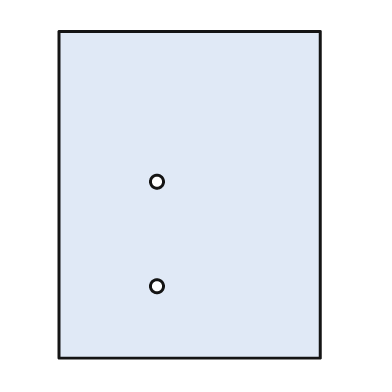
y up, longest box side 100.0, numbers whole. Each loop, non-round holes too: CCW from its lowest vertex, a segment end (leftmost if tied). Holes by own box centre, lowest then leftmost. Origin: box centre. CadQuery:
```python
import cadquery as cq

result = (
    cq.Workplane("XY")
    .moveTo(-40.0, -50.0)
    .lineTo(40.0, -50.0)
    .lineTo(40.0, 50.0)
    .lineTo(-40.0, 50.0)
    .close()
    .moveTo(-10.0, -28.0)
    .circle(2.0)
    .moveTo(-10.0, 4.0)
    .circle(2.0)
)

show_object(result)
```